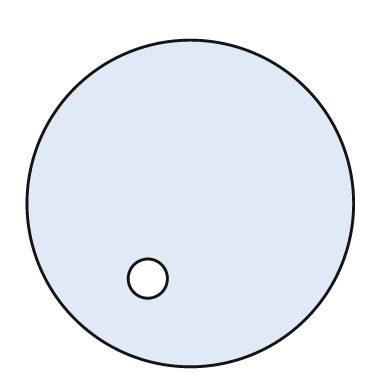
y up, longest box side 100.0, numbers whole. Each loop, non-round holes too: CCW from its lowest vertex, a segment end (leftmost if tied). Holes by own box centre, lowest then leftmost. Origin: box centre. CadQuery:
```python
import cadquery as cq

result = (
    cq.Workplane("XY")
    .moveTo(0.0, 0.0)
    .circle(50.0)
    .moveTo(-13.0, -23.0)
    .circle(6.0)
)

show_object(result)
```